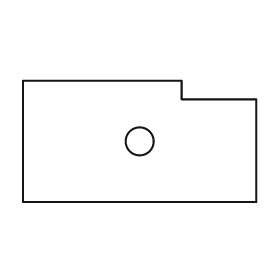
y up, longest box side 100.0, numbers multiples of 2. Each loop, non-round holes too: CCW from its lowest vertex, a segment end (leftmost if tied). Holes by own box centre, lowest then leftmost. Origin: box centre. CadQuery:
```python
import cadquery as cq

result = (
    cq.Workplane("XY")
    .moveTo(-50.0, -26.0)
    .lineTo(50.0, -26.0)
    .lineTo(50.0, 18.0)
    .lineTo(18.0, 18.0)
    .lineTo(18.0, 26.0)
    .lineTo(-50.0, 26.0)
    .close()
    .moveTo(0.0, 0.0)
    .circle(6.0)
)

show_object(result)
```